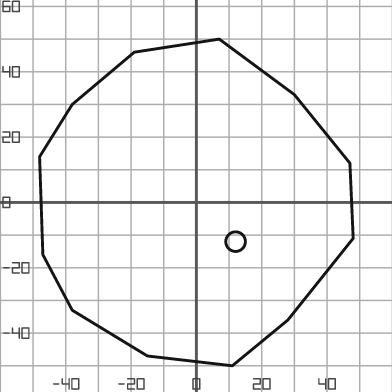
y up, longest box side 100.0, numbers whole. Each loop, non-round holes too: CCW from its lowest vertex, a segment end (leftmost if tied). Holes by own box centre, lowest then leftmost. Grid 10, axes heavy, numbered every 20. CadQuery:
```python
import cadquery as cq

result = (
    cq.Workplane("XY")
    .moveTo(11.0, -50.0)
    .lineTo(28.0, -36.0)
    .lineTo(48.0, -11.0)
    .lineTo(47.0, 12.0)
    .lineTo(30.0, 33.0)
    .lineTo(7.0, 50.0)
    .lineTo(-19.0, 46.0)
    .lineTo(-38.0, 30.0)
    .lineTo(-48.0, 14.0)
    .lineTo(-47.0, -16.0)
    .lineTo(-38.0, -33.0)
    .lineTo(-15.0, -47.0)
    .close()
    .moveTo(12.0, -12.0)
    .circle(3.0)
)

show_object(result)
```